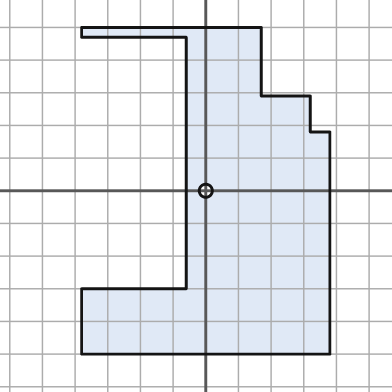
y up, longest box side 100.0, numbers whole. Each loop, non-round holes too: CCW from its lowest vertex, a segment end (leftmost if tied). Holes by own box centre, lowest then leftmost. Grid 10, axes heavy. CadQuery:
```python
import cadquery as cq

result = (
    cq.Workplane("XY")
    .moveTo(-38.0, -50.0)
    .lineTo(38.0, -50.0)
    .lineTo(38.0, 18.0)
    .lineTo(32.0, 18.0)
    .lineTo(32.0, 29.0)
    .lineTo(17.0, 29.0)
    .lineTo(17.0, 50.0)
    .lineTo(-38.0, 50.0)
    .lineTo(-38.0, 47.0)
    .lineTo(-6.0, 47.0)
    .lineTo(-6.0, -30.0)
    .lineTo(-38.0, -30.0)
    .close()
    .moveTo(0.0, 0.0)
    .circle(2.0)
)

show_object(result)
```